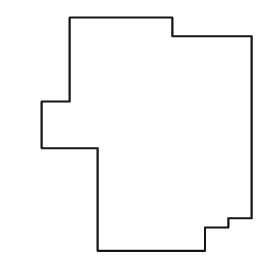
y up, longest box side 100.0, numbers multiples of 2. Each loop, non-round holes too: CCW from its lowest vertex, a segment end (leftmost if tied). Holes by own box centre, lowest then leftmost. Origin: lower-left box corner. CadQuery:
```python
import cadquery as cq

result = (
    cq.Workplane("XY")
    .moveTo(24.0, 0.0)
    .lineTo(70.0, 0.0)
    .lineTo(70.0, 10.0)
    .lineTo(80.0, 10.0)
    .lineTo(80.0, 14.0)
    .lineTo(90.0, 14.0)
    .lineTo(90.0, 92.0)
    .lineTo(56.0, 92.0)
    .lineTo(56.0, 100.0)
    .lineTo(12.0, 100.0)
    .lineTo(12.0, 64.0)
    .lineTo(0.0, 64.0)
    .lineTo(0.0, 44.0)
    .lineTo(24.0, 44.0)
    .close()
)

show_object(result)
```